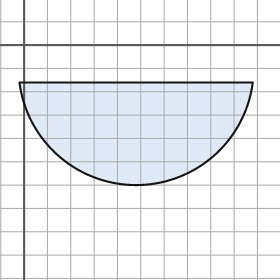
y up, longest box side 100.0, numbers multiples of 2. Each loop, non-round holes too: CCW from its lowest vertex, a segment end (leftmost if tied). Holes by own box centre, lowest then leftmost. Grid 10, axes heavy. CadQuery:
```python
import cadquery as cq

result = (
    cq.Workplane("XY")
    .moveTo(-2.0, -16.0)
    .threePointArc((48.0, -60.0), (98.0, -16.0))
    .close()
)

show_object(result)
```